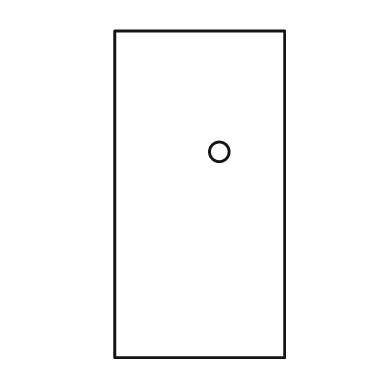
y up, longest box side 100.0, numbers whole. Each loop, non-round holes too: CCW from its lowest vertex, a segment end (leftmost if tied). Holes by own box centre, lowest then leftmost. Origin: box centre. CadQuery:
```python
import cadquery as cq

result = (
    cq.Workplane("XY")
    .moveTo(-26.0, -50.0)
    .lineTo(26.0, -50.0)
    .lineTo(26.0, 50.0)
    .lineTo(-26.0, 50.0)
    .close()
    .moveTo(6.0, 13.0)
    .circle(3.0)
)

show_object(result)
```